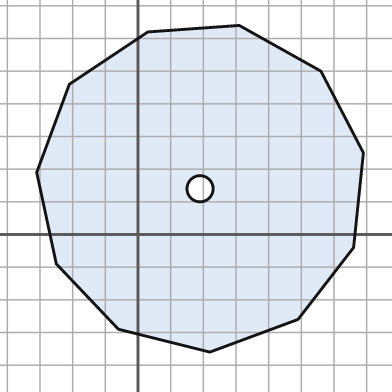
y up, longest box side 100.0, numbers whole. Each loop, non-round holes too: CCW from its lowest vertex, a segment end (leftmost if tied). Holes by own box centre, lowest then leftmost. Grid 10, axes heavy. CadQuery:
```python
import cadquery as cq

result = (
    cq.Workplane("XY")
    .moveTo(22.0, -36.0)
    .lineTo(49.0, -26.0)
    .lineTo(66.0, -4.0)
    .lineTo(69.0, 25.0)
    .lineTo(56.0, 50.0)
    .lineTo(31.0, 64.0)
    .lineTo(3.0, 62.0)
    .lineTo(-21.0, 46.0)
    .lineTo(-31.0, 19.0)
    .lineTo(-25.0, -9.0)
    .lineTo(-6.0, -29.0)
    .close()
    .moveTo(19.0, 14.0)
    .circle(4.0)
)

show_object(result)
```